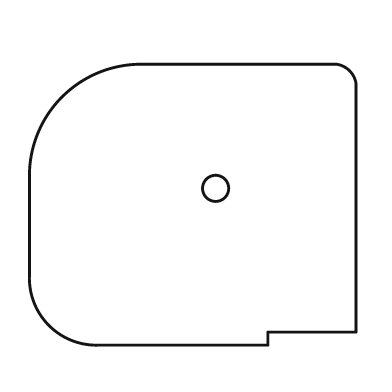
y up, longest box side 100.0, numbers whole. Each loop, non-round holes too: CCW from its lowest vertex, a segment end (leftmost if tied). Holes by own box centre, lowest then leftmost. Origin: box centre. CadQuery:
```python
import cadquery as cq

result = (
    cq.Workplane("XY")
    .moveTo(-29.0, -43.0)
    .lineTo(23.0, -43.0)
    .lineTo(23.0, -39.0)
    .lineTo(50.0, -39.0)
    .lineTo(50.0, 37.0)
    .threePointArc((48.0, 41.0), (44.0, 43.0))
    .lineTo(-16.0, 43.0)
    .threePointArc((-40.0, 33.0), (-50.0, 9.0))
    .lineTo(-50.0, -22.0)
    .threePointArc((-44.0, -37.0), (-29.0, -43.0))
    .close()
    .moveTo(7.0, 5.0)
    .circle(4.0)
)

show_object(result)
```